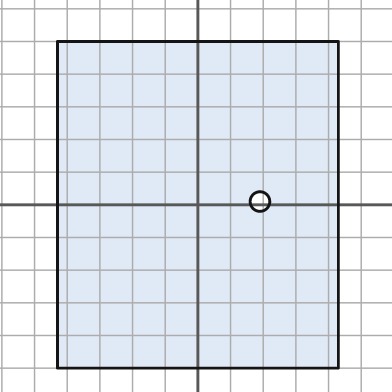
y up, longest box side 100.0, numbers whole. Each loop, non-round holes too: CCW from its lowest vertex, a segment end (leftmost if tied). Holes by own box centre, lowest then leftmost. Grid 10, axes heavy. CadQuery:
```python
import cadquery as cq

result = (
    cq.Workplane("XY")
    .moveTo(-43.0, -50.0)
    .lineTo(43.0, -50.0)
    .lineTo(43.0, 50.0)
    .lineTo(-43.0, 50.0)
    .close()
    .moveTo(19.0, 1.0)
    .circle(3.0)
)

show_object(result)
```